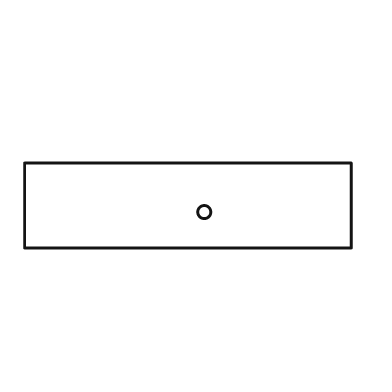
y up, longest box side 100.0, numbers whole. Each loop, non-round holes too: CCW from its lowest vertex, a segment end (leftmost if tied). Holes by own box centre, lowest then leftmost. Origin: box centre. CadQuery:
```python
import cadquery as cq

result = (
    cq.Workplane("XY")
    .moveTo(-50.0, -13.0)
    .lineTo(50.0, -13.0)
    .lineTo(50.0, 13.0)
    .lineTo(-50.0, 13.0)
    .close()
    .moveTo(5.0, -2.0)
    .circle(2.0)
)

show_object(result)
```